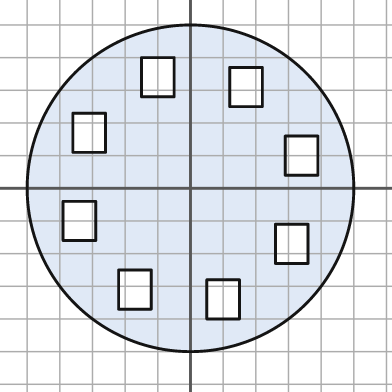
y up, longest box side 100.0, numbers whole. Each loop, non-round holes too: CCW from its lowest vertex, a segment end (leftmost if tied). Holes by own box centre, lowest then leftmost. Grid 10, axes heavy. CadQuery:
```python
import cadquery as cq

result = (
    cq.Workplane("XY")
    .moveTo(0.0, 0.0)
    .circle(50.0)
    .moveTo(5.0, -40.0)
    .lineTo(15.0, -40.0)
    .lineTo(15.0, -28.0)
    .lineTo(5.0, -28.0)
    .close()
    .moveTo(-22.0, -37.0)
    .lineTo(-12.0, -37.0)
    .lineTo(-12.0, -25.0)
    .lineTo(-22.0, -25.0)
    .close()
    .moveTo(26.0, -23.0)
    .lineTo(36.0, -23.0)
    .lineTo(36.0, -11.0)
    .lineTo(26.0, -11.0)
    .close()
    .moveTo(-39.0, -16.0)
    .lineTo(-29.0, -16.0)
    .lineTo(-29.0, -4.0)
    .lineTo(-39.0, -4.0)
    .close()
    .moveTo(29.0, 4.0)
    .lineTo(39.0, 4.0)
    .lineTo(39.0, 16.0)
    .lineTo(29.0, 16.0)
    .close()
    .moveTo(-36.0, 11.0)
    .lineTo(-26.0, 11.0)
    .lineTo(-26.0, 23.0)
    .lineTo(-36.0, 23.0)
    .close()
    .moveTo(12.0, 25.0)
    .lineTo(22.0, 25.0)
    .lineTo(22.0, 37.0)
    .lineTo(12.0, 37.0)
    .close()
    .moveTo(-15.0, 28.0)
    .lineTo(-5.0, 28.0)
    .lineTo(-5.0, 40.0)
    .lineTo(-15.0, 40.0)
    .close()
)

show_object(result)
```